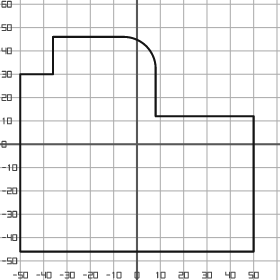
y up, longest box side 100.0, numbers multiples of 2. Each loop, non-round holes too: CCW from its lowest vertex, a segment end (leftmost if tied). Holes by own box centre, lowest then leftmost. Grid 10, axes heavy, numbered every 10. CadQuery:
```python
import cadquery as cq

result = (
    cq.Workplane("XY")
    .moveTo(-50.0, -46.0)
    .lineTo(50.0, -46.0)
    .lineTo(50.0, 12.0)
    .lineTo(8.0, 12.0)
    .lineTo(8.0, 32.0)
    .threePointArc((4.0, 42.0), (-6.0, 46.0))
    .lineTo(-36.0, 46.0)
    .lineTo(-36.0, 30.0)
    .lineTo(-50.0, 30.0)
    .close()
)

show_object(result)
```